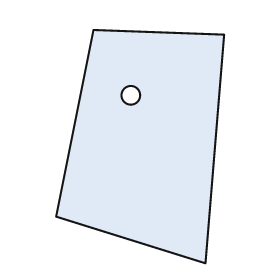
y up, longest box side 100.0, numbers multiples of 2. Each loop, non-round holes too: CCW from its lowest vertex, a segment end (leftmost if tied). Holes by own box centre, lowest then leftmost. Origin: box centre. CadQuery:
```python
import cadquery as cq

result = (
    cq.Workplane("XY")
    .moveTo(28.0, -50.0)
    .lineTo(36.0, 48.0)
    .lineTo(-20.0, 50.0)
    .lineTo(-36.0, -30.0)
    .close()
    .moveTo(-4.0, 22.0)
    .circle(4.0)
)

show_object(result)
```